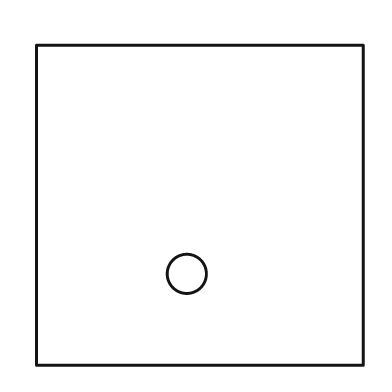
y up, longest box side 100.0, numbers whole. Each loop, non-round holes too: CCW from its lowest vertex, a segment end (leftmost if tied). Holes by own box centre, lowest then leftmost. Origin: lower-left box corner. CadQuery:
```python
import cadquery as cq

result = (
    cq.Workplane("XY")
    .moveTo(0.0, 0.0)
    .lineTo(100.0, 0.0)
    .lineTo(100.0, 98.0)
    .lineTo(0.0, 98.0)
    .close()
    .moveTo(46.0, 28.0)
    .circle(6.0)
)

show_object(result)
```